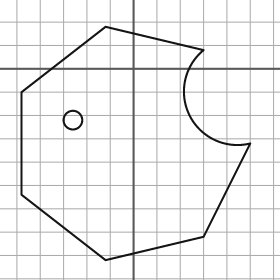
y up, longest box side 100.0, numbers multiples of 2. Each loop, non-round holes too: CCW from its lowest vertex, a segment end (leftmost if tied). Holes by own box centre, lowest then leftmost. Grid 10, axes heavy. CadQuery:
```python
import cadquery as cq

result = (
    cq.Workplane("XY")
    .moveTo(-12.0, -82.0)
    .lineTo(30.0, -72.0)
    .lineTo(50.0, -32.0)
    .threePointArc((24.0, -20.0), (30.0, 8.0))
    .lineTo(-12.0, 18.0)
    .lineTo(-48.0, -10.0)
    .lineTo(-48.0, -54.0)
    .close()
    .moveTo(-26.0, -22.0)
    .circle(4.0)
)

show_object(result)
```